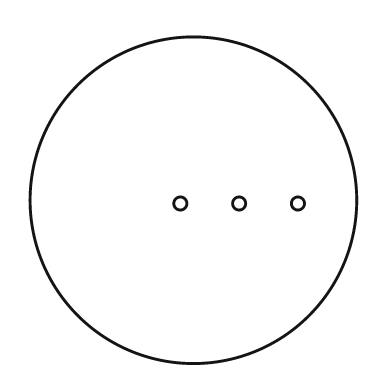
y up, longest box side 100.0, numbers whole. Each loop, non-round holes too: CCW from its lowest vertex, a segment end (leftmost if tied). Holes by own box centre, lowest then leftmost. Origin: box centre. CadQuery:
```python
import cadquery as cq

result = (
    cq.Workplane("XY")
    .moveTo(0.0, 0.0)
    .circle(50.0)
    .moveTo(-4.0, -1.0)
    .circle(2.0)
    .moveTo(14.0, -1.0)
    .circle(2.0)
    .moveTo(32.0, -1.0)
    .circle(2.0)
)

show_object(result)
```